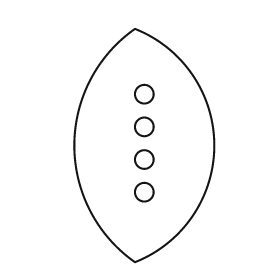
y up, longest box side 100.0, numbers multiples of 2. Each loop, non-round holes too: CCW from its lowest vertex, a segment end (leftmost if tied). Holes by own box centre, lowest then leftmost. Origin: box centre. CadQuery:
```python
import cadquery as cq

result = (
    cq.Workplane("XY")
    .moveTo(-4.0, -50.0)
    .threePointArc((30.0, 0.0), (-4.0, 50.0))
    .threePointArc((-30.0, 0.0), (-4.0, -50.0))
    .close()
    .moveTo(0.0, -20.0)
    .circle(4.0)
    .moveTo(0.0, -6.0)
    .circle(4.0)
    .moveTo(0.0, 8.0)
    .circle(4.0)
    .moveTo(0.0, 22.0)
    .circle(4.0)
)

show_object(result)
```